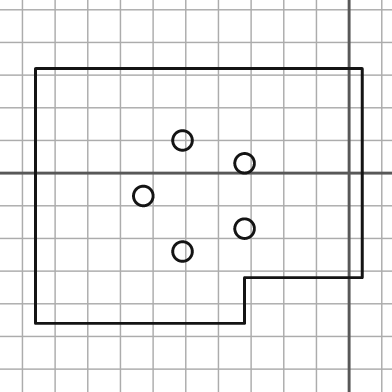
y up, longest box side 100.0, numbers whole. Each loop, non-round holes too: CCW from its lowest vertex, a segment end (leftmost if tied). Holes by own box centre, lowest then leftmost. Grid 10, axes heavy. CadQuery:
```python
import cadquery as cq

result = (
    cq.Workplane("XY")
    .moveTo(-96.0, -46.0)
    .lineTo(-32.0, -46.0)
    .lineTo(-32.0, -32.0)
    .lineTo(4.0, -32.0)
    .lineTo(4.0, 32.0)
    .lineTo(-96.0, 32.0)
    .close()
    .moveTo(-51.0, -24.0)
    .circle(3.0)
    .moveTo(-32.0, -17.0)
    .circle(3.0)
    .moveTo(-63.0, -7.0)
    .circle(3.0)
    .moveTo(-32.0, 3.0)
    .circle(3.0)
    .moveTo(-51.0, 10.0)
    .circle(3.0)
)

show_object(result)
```